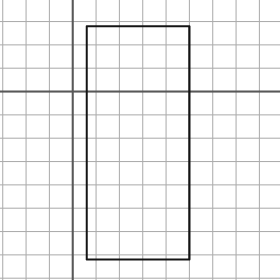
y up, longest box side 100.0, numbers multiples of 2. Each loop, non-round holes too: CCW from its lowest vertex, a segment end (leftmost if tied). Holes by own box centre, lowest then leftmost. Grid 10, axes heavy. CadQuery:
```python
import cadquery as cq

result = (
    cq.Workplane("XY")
    .moveTo(6.0, -72.0)
    .lineTo(50.0, -72.0)
    .lineTo(50.0, 28.0)
    .lineTo(6.0, 28.0)
    .close()
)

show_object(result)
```